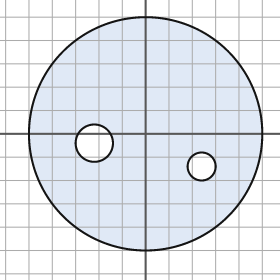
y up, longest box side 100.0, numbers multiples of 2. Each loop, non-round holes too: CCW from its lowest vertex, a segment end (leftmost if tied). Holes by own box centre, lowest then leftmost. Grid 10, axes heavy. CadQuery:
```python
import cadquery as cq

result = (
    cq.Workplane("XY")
    .moveTo(0.0, 0.0)
    .circle(50.0)
    .moveTo(24.0, -14.0)
    .circle(6.0)
    .moveTo(-22.0, -4.0)
    .circle(8.0)
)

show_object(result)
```